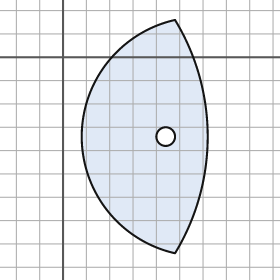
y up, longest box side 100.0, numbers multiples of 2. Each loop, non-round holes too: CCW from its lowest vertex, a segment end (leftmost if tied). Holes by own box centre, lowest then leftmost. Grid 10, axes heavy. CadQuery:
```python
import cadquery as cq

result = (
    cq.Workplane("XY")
    .moveTo(48.0, -84.0)
    .threePointArc((62.0, -34.0), (48.0, 16.0))
    .threePointArc((8.0, -34.0), (48.0, -84.0))
    .close()
    .moveTo(44.0, -34.0)
    .circle(4.0)
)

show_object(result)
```